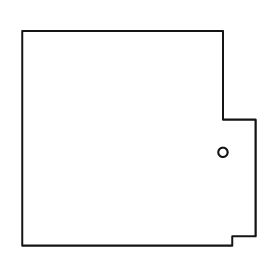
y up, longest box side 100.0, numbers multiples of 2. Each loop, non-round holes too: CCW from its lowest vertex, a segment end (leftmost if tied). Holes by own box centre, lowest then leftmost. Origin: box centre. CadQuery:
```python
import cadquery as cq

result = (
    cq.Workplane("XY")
    .moveTo(-50.0, -46.0)
    .lineTo(40.0, -46.0)
    .lineTo(40.0, -42.0)
    .lineTo(50.0, -42.0)
    .lineTo(50.0, 8.0)
    .lineTo(36.0, 8.0)
    .lineTo(36.0, 46.0)
    .lineTo(-50.0, 46.0)
    .close()
    .moveTo(36.0, -6.0)
    .circle(2.0)
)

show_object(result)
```